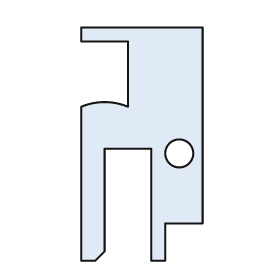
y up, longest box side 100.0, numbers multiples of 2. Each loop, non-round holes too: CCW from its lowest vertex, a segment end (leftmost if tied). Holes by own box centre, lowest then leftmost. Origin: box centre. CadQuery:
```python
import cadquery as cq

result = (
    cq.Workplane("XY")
    .moveTo(-26.0, -50.0)
    .lineTo(-20.0, -50.0)
    .lineTo(-16.0, -46.0)
    .lineTo(-16.0, -2.0)
    .lineTo(4.0, -2.0)
    .lineTo(4.0, -50.0)
    .lineTo(10.0, -50.0)
    .lineTo(10.0, -34.0)
    .lineTo(26.0, -34.0)
    .lineTo(26.0, 50.0)
    .lineTo(-26.0, 50.0)
    .lineTo(-26.0, 44.0)
    .lineTo(-6.0, 44.0)
    .lineTo(-6.0, 16.0)
    .threePointArc((-16.0, 18.0), (-26.0, 16.0))
    .close()
    .moveTo(16.0, -4.0)
    .circle(6.0)
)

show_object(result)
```